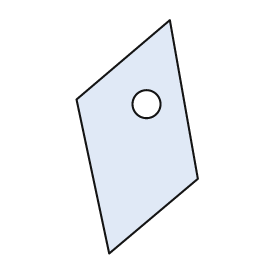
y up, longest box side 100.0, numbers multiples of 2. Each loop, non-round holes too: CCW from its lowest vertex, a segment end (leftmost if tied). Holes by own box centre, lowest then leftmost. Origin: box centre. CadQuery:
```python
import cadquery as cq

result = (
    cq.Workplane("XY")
    .moveTo(-12.0, -50.0)
    .lineTo(26.0, -18.0)
    .lineTo(14.0, 50.0)
    .lineTo(-26.0, 16.0)
    .close()
    .moveTo(4.0, 14.0)
    .circle(6.0)
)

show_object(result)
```